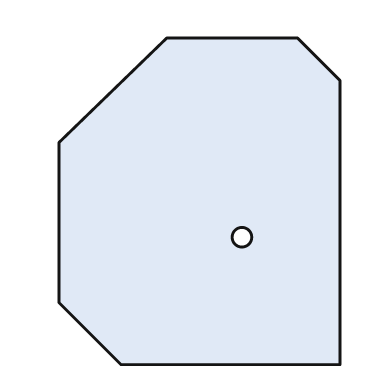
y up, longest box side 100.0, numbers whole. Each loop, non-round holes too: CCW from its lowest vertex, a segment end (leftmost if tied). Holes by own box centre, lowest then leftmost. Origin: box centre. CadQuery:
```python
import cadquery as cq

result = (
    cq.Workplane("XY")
    .moveTo(-24.0, -50.0)
    .lineTo(43.0, -50.0)
    .lineTo(43.0, 37.0)
    .lineTo(30.0, 50.0)
    .lineTo(-10.0, 50.0)
    .lineTo(-43.0, 18.0)
    .lineTo(-43.0, -31.0)
    .close()
    .moveTo(13.0, -11.0)
    .circle(3.0)
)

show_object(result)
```